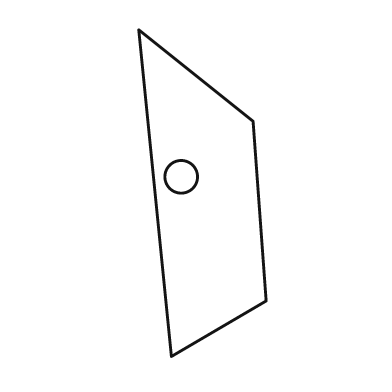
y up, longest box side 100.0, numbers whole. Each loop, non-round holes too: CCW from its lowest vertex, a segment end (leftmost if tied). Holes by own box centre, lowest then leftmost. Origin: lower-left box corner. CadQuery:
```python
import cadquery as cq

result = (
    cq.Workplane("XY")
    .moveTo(10.0, 0.0)
    .lineTo(39.0, 17.0)
    .lineTo(35.0, 72.0)
    .lineTo(0.0, 100.0)
    .close()
    .moveTo(13.0, 55.0)
    .circle(5.0)
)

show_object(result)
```